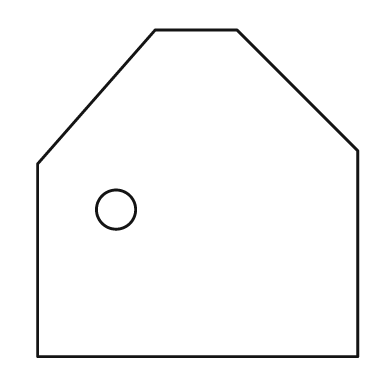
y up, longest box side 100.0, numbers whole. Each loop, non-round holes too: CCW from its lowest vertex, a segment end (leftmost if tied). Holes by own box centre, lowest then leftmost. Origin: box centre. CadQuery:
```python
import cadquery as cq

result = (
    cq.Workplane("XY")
    .moveTo(-49.0, -50.0)
    .lineTo(49.0, -50.0)
    .lineTo(49.0, 13.0)
    .lineTo(12.0, 50.0)
    .lineTo(-13.0, 50.0)
    .lineTo(-49.0, 9.0)
    .close()
    .moveTo(-25.0, -5.0)
    .circle(6.0)
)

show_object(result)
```